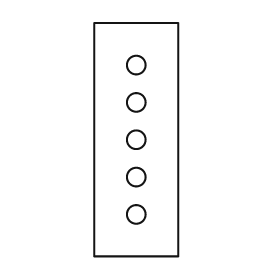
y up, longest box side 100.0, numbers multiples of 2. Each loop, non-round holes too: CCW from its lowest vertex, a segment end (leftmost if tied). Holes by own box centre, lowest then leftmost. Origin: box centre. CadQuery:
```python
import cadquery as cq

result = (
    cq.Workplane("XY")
    .moveTo(-18.0, -50.0)
    .lineTo(18.0, -50.0)
    .lineTo(18.0, 50.0)
    .lineTo(-18.0, 50.0)
    .close()
    .moveTo(0.0, -32.0)
    .circle(4.0)
    .moveTo(0.0, -16.0)
    .circle(4.0)
    .moveTo(0.0, 0.0)
    .circle(4.0)
    .moveTo(0.0, 16.0)
    .circle(4.0)
    .moveTo(0.0, 32.0)
    .circle(4.0)
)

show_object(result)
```